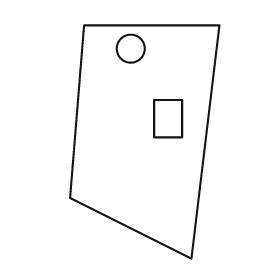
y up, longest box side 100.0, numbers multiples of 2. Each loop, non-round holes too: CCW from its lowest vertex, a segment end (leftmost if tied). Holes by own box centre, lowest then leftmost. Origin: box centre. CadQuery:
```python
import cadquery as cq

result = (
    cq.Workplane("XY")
    .moveTo(20.0, -50.0)
    .lineTo(32.0, 50.0)
    .lineTo(-26.0, 50.0)
    .lineTo(-32.0, -24.0)
    .close()
    .moveTo(4.0, 2.0)
    .lineTo(16.0, 2.0)
    .lineTo(16.0, 18.0)
    .lineTo(4.0, 18.0)
    .close()
    .moveTo(-6.0, 40.0)
    .circle(6.0)
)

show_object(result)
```